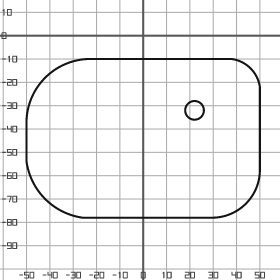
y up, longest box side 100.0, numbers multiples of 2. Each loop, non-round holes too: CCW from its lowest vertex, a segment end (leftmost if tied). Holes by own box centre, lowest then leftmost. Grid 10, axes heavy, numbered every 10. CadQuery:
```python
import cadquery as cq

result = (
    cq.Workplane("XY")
    .moveTo(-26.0, -78.0)
    .lineTo(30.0, -78.0)
    .threePointArc((44.0, -72.0), (50.0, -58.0))
    .lineTo(50.0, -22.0)
    .threePointArc((46.0, -14.0), (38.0, -10.0))
    .lineTo(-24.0, -10.0)
    .threePointArc((-42.0, -18.0), (-50.0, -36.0))
    .lineTo(-50.0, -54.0)
    .threePointArc((-42.0, -70.0), (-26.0, -78.0))
    .close()
    .moveTo(22.0, -32.0)
    .circle(4.0)
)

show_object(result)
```